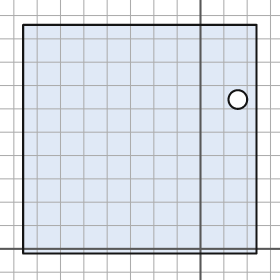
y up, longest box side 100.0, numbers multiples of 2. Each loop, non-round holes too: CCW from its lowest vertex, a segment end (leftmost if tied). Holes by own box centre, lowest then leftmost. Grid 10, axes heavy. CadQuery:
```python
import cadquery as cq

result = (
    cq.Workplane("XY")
    .moveTo(-76.0, -2.0)
    .lineTo(24.0, -2.0)
    .lineTo(24.0, 96.0)
    .lineTo(-76.0, 96.0)
    .close()
    .moveTo(16.0, 64.0)
    .circle(4.0)
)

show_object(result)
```